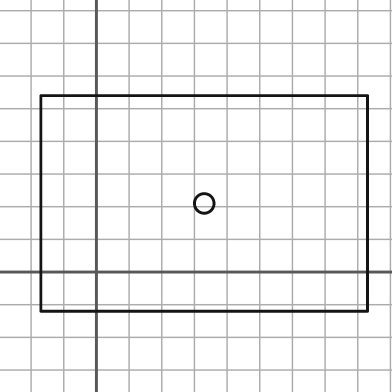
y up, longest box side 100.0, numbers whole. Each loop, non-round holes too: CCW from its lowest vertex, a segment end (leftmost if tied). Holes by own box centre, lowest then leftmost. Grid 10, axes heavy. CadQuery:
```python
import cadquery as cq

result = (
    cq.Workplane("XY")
    .moveTo(-17.0, -12.0)
    .lineTo(83.0, -12.0)
    .lineTo(83.0, 54.0)
    .lineTo(-17.0, 54.0)
    .close()
    .moveTo(33.0, 21.0)
    .circle(3.0)
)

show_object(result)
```